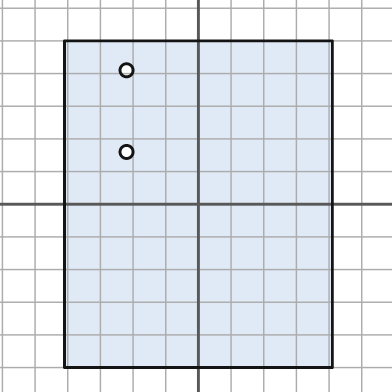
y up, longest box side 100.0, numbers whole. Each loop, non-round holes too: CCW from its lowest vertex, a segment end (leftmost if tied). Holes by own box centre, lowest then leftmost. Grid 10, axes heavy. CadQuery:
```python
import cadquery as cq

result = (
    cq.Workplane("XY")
    .moveTo(-41.0, -50.0)
    .lineTo(41.0, -50.0)
    .lineTo(41.0, 50.0)
    .lineTo(-41.0, 50.0)
    .close()
    .moveTo(-22.0, 16.0)
    .circle(2.0)
    .moveTo(-22.0, 41.0)
    .circle(2.0)
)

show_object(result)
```